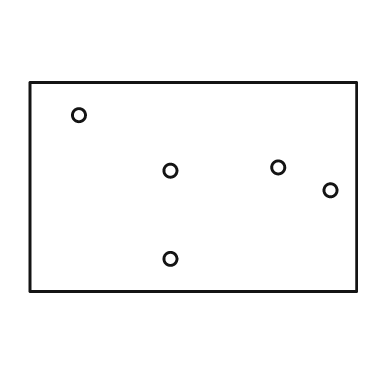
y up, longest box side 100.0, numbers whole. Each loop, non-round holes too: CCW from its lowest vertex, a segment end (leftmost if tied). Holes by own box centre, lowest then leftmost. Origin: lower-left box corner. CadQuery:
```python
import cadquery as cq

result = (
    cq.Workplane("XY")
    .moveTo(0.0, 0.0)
    .lineTo(100.0, 0.0)
    .lineTo(100.0, 64.0)
    .lineTo(0.0, 64.0)
    .close()
    .moveTo(43.0, 10.0)
    .circle(2.0)
    .moveTo(92.0, 31.0)
    .circle(2.0)
    .moveTo(43.0, 37.0)
    .circle(2.0)
    .moveTo(76.0, 38.0)
    .circle(2.0)
    .moveTo(15.0, 54.0)
    .circle(2.0)
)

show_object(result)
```